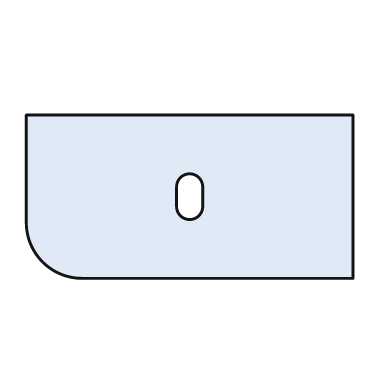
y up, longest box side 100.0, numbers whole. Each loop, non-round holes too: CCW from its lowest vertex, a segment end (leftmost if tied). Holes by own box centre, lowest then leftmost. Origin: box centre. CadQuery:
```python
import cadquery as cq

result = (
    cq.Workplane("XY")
    .moveTo(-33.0, -25.0)
    .lineTo(50.0, -25.0)
    .lineTo(50.0, 25.0)
    .lineTo(-50.0, 25.0)
    .lineTo(-50.0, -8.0)
    .threePointArc((-45.0, -20.0), (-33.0, -25.0))
    .close()
    .moveTo(-4.0, -3.0)
    .threePointArc((0.0, -7.0), (4.0, -3.0))
    .lineTo(4.0, 3.0)
    .threePointArc((0.0, 7.0), (-4.0, 3.0))
    .close()
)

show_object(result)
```